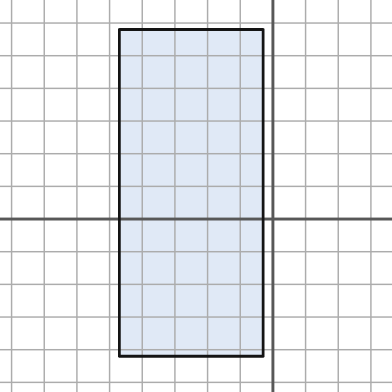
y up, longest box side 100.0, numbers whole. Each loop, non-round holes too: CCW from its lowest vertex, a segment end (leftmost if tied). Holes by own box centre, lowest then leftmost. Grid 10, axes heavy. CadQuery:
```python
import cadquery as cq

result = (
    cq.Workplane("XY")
    .moveTo(-47.0, -42.0)
    .lineTo(-3.0, -42.0)
    .lineTo(-3.0, 58.0)
    .lineTo(-47.0, 58.0)
    .close()
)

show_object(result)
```